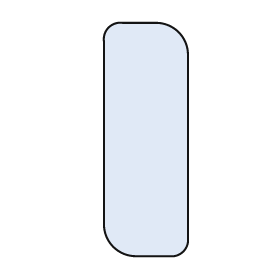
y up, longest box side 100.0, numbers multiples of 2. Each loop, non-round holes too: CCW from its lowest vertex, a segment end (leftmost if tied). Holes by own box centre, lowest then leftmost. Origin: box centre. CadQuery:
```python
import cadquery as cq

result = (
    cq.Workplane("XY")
    .moveTo(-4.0, -50.0)
    .lineTo(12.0, -50.0)
    .threePointArc((16.0, -48.0), (18.0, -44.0))
    .lineTo(18.0, 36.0)
    .threePointArc((14.0, 46.0), (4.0, 50.0))
    .lineTo(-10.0, 50.0)
    .threePointArc((-16.0, 48.0), (-18.0, 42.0))
    .lineTo(-18.0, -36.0)
    .threePointArc((-14.0, -46.0), (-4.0, -50.0))
    .close()
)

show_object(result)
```